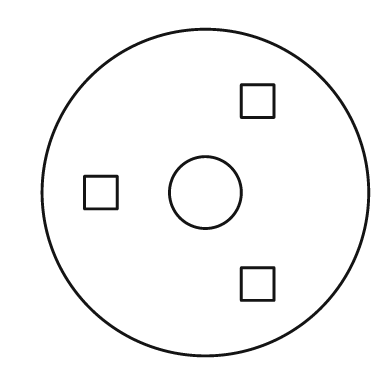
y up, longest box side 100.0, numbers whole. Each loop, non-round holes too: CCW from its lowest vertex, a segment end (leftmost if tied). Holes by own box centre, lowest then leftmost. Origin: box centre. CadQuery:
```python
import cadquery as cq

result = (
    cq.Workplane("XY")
    .moveTo(0.0, 0.0)
    .circle(50.0)
    .moveTo(11.0, -33.0)
    .lineTo(21.0, -33.0)
    .lineTo(21.0, -23.0)
    .lineTo(11.0, -23.0)
    .close()
    .moveTo(-37.0, -5.0)
    .lineTo(-27.0, -5.0)
    .lineTo(-27.0, 5.0)
    .lineTo(-37.0, 5.0)
    .close()
    .moveTo(0.0, 0.0)
    .circle(11.0)
    .moveTo(11.0, 23.0)
    .lineTo(21.0, 23.0)
    .lineTo(21.0, 33.0)
    .lineTo(11.0, 33.0)
    .close()
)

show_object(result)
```